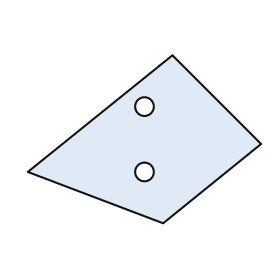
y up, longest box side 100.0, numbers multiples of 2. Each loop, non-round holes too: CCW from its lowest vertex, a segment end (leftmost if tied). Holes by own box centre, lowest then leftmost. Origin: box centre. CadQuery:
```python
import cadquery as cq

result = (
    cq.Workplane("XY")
    .moveTo(8.0, -36.0)
    .lineTo(50.0, -2.0)
    .lineTo(12.0, 36.0)
    .lineTo(-50.0, -14.0)
    .close()
    .moveTo(0.0, -14.0)
    .circle(4.0)
    .moveTo(0.0, 14.0)
    .circle(4.0)
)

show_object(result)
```